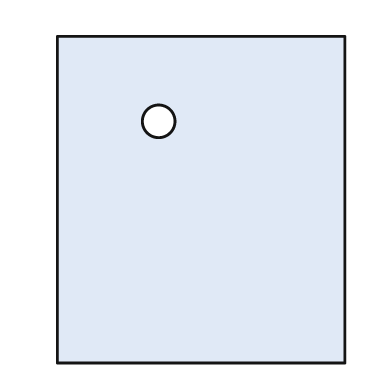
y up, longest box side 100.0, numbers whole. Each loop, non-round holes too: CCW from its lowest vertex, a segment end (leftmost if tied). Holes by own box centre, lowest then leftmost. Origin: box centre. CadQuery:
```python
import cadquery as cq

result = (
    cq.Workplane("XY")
    .moveTo(-44.0, -50.0)
    .lineTo(44.0, -50.0)
    .lineTo(44.0, 50.0)
    .lineTo(-44.0, 50.0)
    .close()
    .moveTo(-13.0, 24.0)
    .circle(5.0)
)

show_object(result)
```